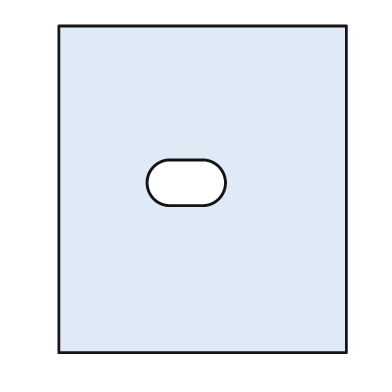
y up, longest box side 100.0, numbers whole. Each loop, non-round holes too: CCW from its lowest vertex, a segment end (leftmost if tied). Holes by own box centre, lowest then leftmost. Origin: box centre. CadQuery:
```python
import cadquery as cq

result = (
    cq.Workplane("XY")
    .moveTo(-44.0, -50.0)
    .lineTo(44.0, -50.0)
    .lineTo(44.0, 50.0)
    .lineTo(-44.0, 50.0)
    .close()
    .moveTo(-10.0, -5.0)
    .lineTo(0.0, -5.0)
    .threePointArc((7.0, 2.0), (0.0, 9.0))
    .lineTo(-10.0, 9.0)
    .threePointArc((-17.0, 2.0), (-10.0, -5.0))
    .close()
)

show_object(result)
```